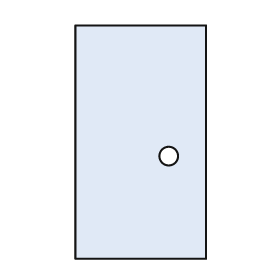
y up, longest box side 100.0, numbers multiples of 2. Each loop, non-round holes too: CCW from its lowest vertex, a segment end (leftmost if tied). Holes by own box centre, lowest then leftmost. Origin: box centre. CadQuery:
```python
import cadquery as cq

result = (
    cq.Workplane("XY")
    .moveTo(-28.0, -50.0)
    .lineTo(28.0, -50.0)
    .lineTo(28.0, 50.0)
    .lineTo(-28.0, 50.0)
    .close()
    .moveTo(12.0, -6.0)
    .circle(4.0)
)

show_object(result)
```